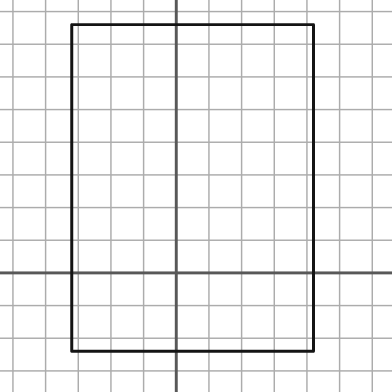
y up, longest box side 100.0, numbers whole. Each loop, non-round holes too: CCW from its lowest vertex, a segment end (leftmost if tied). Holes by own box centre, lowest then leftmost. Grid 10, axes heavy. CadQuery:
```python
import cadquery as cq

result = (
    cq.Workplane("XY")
    .moveTo(-32.0, -24.0)
    .lineTo(42.0, -24.0)
    .lineTo(42.0, 76.0)
    .lineTo(-32.0, 76.0)
    .close()
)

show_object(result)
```